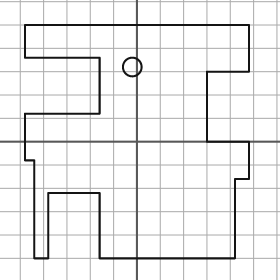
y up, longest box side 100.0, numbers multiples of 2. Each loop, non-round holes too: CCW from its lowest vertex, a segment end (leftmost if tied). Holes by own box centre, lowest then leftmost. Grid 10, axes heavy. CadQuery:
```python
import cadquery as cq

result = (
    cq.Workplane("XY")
    .moveTo(-44.0, -50.0)
    .lineTo(-38.0, -50.0)
    .lineTo(-38.0, -22.0)
    .lineTo(-16.0, -22.0)
    .lineTo(-16.0, -50.0)
    .lineTo(42.0, -50.0)
    .lineTo(42.0, -16.0)
    .lineTo(48.0, -16.0)
    .lineTo(48.0, 0.0)
    .lineTo(30.0, 0.0)
    .lineTo(30.0, 30.0)
    .lineTo(48.0, 30.0)
    .lineTo(48.0, 50.0)
    .lineTo(-48.0, 50.0)
    .lineTo(-48.0, 36.0)
    .lineTo(-16.0, 36.0)
    .lineTo(-16.0, 12.0)
    .lineTo(-48.0, 12.0)
    .lineTo(-48.0, -8.0)
    .lineTo(-44.0, -8.0)
    .close()
    .moveTo(-2.0, 32.0)
    .circle(4.0)
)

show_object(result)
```